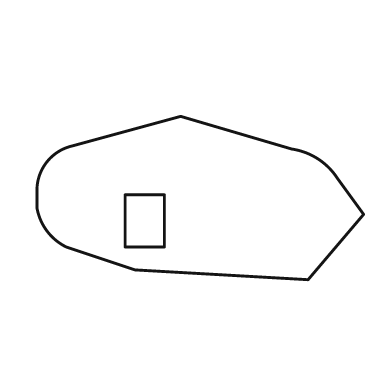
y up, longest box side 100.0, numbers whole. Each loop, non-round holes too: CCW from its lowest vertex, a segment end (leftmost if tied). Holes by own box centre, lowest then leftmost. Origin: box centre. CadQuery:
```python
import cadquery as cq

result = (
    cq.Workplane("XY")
    .moveTo(33.0, -25.0)
    .lineTo(50.0, -5.0)
    .lineTo(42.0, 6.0)
    .threePointArc((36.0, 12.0), (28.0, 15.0))
    .lineTo(-6.0, 25.0)
    .lineTo(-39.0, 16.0)
    .threePointArc((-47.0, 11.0), (-50.0, 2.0))
    .lineTo(-50.0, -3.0)
    .threePointArc((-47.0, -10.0), (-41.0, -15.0))
    .lineTo(-20.0, -22.0)
    .close()
    .moveTo(-23.0, -15.0)
    .lineTo(-11.0, -15.0)
    .lineTo(-11.0, 1.0)
    .lineTo(-23.0, 1.0)
    .close()
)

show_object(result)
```